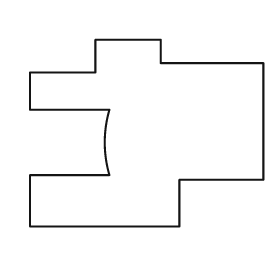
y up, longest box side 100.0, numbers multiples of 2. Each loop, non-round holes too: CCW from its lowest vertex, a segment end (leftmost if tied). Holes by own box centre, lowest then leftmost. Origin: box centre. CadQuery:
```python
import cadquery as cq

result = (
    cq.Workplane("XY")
    .moveTo(-50.0, -40.0)
    .lineTo(14.0, -40.0)
    .lineTo(14.0, -20.0)
    .lineTo(50.0, -20.0)
    .lineTo(50.0, 30.0)
    .lineTo(6.0, 30.0)
    .lineTo(6.0, 40.0)
    .lineTo(-22.0, 40.0)
    .lineTo(-22.0, 26.0)
    .lineTo(-50.0, 26.0)
    .lineTo(-50.0, 10.0)
    .lineTo(-16.0, 10.0)
    .threePointArc((-18.0, -4.0), (-16.0, -18.0))
    .lineTo(-50.0, -18.0)
    .close()
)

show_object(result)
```